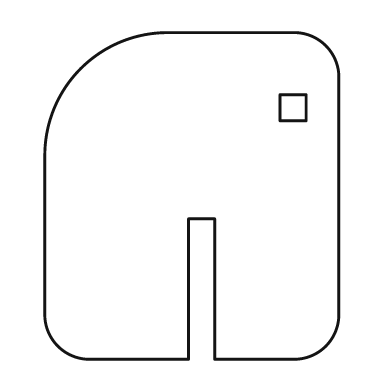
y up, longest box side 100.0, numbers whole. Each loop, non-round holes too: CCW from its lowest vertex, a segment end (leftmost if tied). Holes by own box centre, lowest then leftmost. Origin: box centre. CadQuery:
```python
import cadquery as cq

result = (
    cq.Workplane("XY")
    .moveTo(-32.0, -50.0)
    .lineTo(-1.0, -50.0)
    .lineTo(-1.0, -7.0)
    .lineTo(7.0, -7.0)
    .lineTo(7.0, -50.0)
    .lineTo(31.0, -50.0)
    .threePointArc((41.0, -46.0), (45.0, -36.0))
    .lineTo(45.0, 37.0)
    .threePointArc((41.0, 46.0), (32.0, 50.0))
    .lineTo(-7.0, 50.0)
    .threePointArc((-34.0, 39.0), (-45.0, 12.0))
    .lineTo(-45.0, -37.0)
    .threePointArc((-41.0, -46.0), (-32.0, -50.0))
    .close()
    .moveTo(27.0, 23.0)
    .lineTo(35.0, 23.0)
    .lineTo(35.0, 31.0)
    .lineTo(27.0, 31.0)
    .close()
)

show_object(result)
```